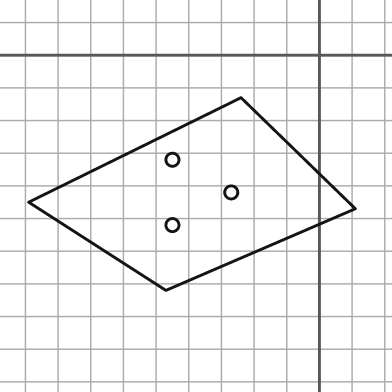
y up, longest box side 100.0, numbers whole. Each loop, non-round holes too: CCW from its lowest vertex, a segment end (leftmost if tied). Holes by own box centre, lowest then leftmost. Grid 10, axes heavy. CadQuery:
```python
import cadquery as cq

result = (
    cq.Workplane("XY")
    .moveTo(-47.0, -72.0)
    .lineTo(11.0, -47.0)
    .lineTo(-24.0, -13.0)
    .lineTo(-89.0, -45.0)
    .close()
    .moveTo(-45.0, -52.0)
    .circle(2.0)
    .moveTo(-27.0, -42.0)
    .circle(2.0)
    .moveTo(-45.0, -32.0)
    .circle(2.0)
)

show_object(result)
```